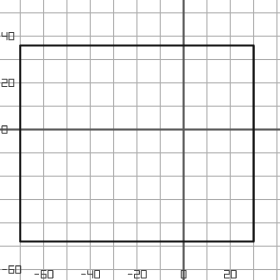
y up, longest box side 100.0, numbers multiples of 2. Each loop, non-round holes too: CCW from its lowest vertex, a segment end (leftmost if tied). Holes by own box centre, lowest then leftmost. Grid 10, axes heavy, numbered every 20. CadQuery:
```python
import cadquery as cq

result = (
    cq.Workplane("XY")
    .moveTo(-70.0, -48.0)
    .lineTo(30.0, -48.0)
    .lineTo(30.0, 36.0)
    .lineTo(-70.0, 36.0)
    .close()
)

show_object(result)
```